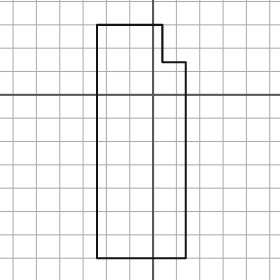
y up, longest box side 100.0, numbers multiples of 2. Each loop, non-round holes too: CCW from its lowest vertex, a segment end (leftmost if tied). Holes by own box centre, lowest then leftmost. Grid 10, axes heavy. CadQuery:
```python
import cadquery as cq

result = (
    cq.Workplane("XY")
    .moveTo(-24.0, -70.0)
    .lineTo(14.0, -70.0)
    .lineTo(14.0, 14.0)
    .lineTo(4.0, 14.0)
    .lineTo(4.0, 30.0)
    .lineTo(-24.0, 30.0)
    .close()
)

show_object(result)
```